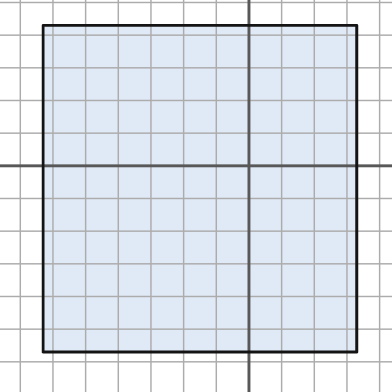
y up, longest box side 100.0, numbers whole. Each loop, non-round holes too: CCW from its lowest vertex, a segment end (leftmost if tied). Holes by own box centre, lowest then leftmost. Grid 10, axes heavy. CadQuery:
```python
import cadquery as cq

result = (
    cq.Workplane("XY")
    .moveTo(-63.0, -57.0)
    .lineTo(33.0, -57.0)
    .lineTo(33.0, 43.0)
    .lineTo(-63.0, 43.0)
    .close()
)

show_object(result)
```